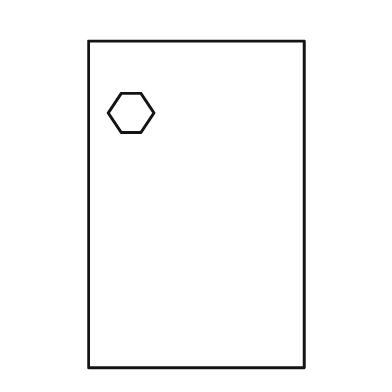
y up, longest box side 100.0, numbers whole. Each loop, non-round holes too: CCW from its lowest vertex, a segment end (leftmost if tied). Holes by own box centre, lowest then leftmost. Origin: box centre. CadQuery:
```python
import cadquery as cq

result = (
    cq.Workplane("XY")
    .moveTo(-33.0, -50.0)
    .lineTo(33.0, -50.0)
    .lineTo(33.0, 50.0)
    .lineTo(-33.0, 50.0)
    .close()
    .moveTo(-23.0, 22.0)
    .lineTo(-17.0, 22.0)
    .lineTo(-13.0, 28.0)
    .lineTo(-17.0, 34.0)
    .lineTo(-23.0, 34.0)
    .lineTo(-27.0, 28.0)
    .close()
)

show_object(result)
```